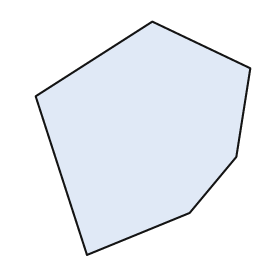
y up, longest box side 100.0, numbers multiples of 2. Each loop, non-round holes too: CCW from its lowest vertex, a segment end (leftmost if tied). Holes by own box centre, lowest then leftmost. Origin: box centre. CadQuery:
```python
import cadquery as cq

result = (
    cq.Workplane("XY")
    .moveTo(-24.0, -50.0)
    .lineTo(20.0, -32.0)
    .lineTo(40.0, -8.0)
    .lineTo(46.0, 30.0)
    .lineTo(4.0, 50.0)
    .lineTo(-46.0, 18.0)
    .close()
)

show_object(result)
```